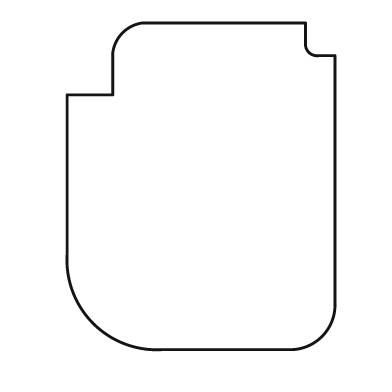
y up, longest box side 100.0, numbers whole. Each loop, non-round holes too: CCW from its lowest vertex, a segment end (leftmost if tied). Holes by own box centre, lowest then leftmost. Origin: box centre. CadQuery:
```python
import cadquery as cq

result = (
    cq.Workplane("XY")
    .moveTo(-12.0, -50.0)
    .lineTo(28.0, -50.0)
    .threePointArc((37.0, -46.0), (41.0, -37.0))
    .lineTo(41.0, 40.0)
    .lineTo(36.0, 40.0)
    .threePointArc((33.0, 41.0), (32.0, 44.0))
    .lineTo(32.0, 50.0)
    .lineTo(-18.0, 50.0)
    .threePointArc((-24.0, 47.0), (-27.0, 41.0))
    .lineTo(-27.0, 28.0)
    .lineTo(-41.0, 28.0)
    .lineTo(-41.0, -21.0)
    .threePointArc((-33.0, -42.0), (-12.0, -50.0))
    .close()
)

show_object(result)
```